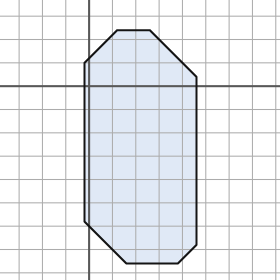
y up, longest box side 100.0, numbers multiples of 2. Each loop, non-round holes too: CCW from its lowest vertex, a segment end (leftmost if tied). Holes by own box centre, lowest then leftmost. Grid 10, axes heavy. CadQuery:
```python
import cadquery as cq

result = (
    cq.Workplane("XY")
    .moveTo(16.0, -76.0)
    .lineTo(38.0, -76.0)
    .lineTo(46.0, -68.0)
    .lineTo(46.0, 4.0)
    .lineTo(26.0, 24.0)
    .lineTo(12.0, 24.0)
    .lineTo(-2.0, 10.0)
    .lineTo(-2.0, -58.0)
    .close()
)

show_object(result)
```